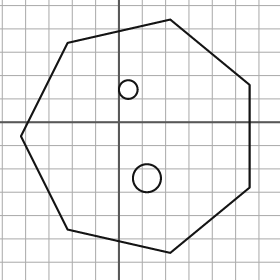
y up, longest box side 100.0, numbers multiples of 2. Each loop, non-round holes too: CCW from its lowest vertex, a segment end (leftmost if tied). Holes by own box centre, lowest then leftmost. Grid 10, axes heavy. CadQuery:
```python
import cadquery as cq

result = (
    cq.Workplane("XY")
    .moveTo(22.0, -56.0)
    .lineTo(56.0, -28.0)
    .lineTo(56.0, 16.0)
    .lineTo(22.0, 44.0)
    .lineTo(-22.0, 34.0)
    .lineTo(-42.0, -6.0)
    .lineTo(-22.0, -46.0)
    .close()
    .moveTo(12.0, -24.0)
    .circle(6.0)
    .moveTo(4.0, 14.0)
    .circle(4.0)
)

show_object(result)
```